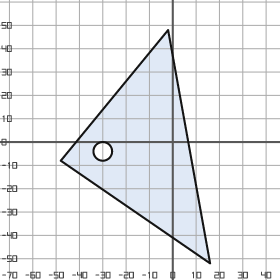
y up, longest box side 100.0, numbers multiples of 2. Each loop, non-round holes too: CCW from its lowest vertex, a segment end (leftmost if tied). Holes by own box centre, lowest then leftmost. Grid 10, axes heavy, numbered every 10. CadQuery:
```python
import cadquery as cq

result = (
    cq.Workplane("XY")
    .moveTo(16.0, -52.0)
    .lineTo(-2.0, 48.0)
    .lineTo(-48.0, -8.0)
    .close()
    .moveTo(-30.0, -4.0)
    .circle(4.0)
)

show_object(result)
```